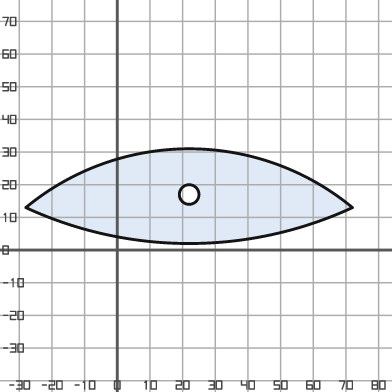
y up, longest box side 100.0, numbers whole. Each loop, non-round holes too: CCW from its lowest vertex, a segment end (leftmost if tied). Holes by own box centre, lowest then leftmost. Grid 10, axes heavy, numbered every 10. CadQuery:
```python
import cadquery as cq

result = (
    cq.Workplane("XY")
    .moveTo(-28.0, 13.0)
    .threePointArc((22.0, 2.0), (72.0, 13.0))
    .threePointArc((22.0, 31.0), (-28.0, 13.0))
    .close()
    .moveTo(22.0, 17.0)
    .circle(3.0)
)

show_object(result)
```